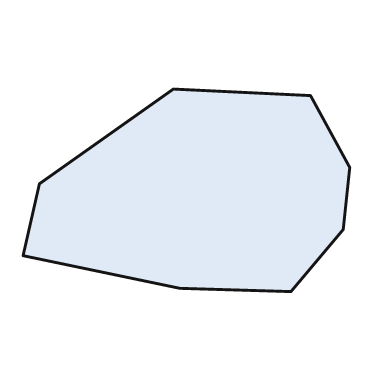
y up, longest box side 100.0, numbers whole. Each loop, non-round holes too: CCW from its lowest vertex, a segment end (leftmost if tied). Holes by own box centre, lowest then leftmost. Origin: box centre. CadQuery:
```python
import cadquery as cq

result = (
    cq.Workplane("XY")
    .moveTo(32.0, -31.0)
    .lineTo(48.0, -12.0)
    .lineTo(50.0, 7.0)
    .lineTo(38.0, 29.0)
    .lineTo(-4.0, 31.0)
    .lineTo(-45.0, 2.0)
    .lineTo(-50.0, -20.0)
    .lineTo(-2.0, -30.0)
    .close()
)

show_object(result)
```